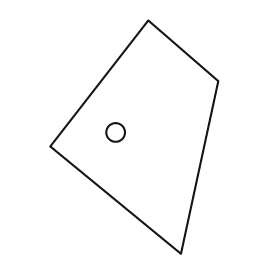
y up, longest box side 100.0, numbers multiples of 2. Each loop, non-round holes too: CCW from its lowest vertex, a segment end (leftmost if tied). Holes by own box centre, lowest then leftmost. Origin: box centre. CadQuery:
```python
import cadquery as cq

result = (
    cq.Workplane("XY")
    .moveTo(20.0, -50.0)
    .lineTo(36.0, 24.0)
    .lineTo(6.0, 50.0)
    .lineTo(-36.0, -4.0)
    .close()
    .moveTo(-8.0, 2.0)
    .circle(4.0)
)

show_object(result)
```